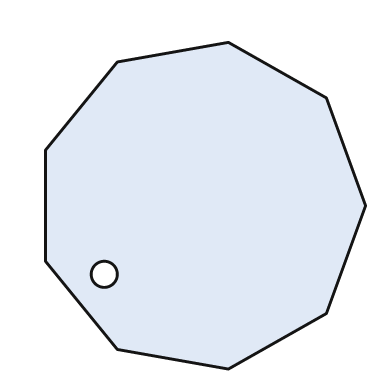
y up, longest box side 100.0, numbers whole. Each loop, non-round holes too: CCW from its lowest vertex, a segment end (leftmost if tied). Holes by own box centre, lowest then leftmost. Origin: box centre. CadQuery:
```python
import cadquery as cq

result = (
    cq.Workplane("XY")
    .moveTo(7.0, -50.0)
    .lineTo(37.0, -33.0)
    .lineTo(49.0, 0.0)
    .lineTo(37.0, 33.0)
    .lineTo(7.0, 50.0)
    .lineTo(-27.0, 44.0)
    .lineTo(-49.0, 17.0)
    .lineTo(-49.0, -17.0)
    .lineTo(-27.0, -44.0)
    .close()
    .moveTo(-31.0, -21.0)
    .circle(4.0)
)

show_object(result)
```